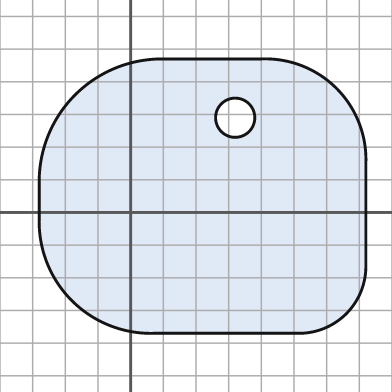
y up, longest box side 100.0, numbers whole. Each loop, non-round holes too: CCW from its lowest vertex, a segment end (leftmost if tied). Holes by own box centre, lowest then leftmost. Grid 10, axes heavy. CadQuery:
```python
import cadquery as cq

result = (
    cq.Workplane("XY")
    .moveTo(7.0, -37.0)
    .lineTo(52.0, -37.0)
    .threePointArc((66.0, -31.0), (72.0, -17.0))
    .lineTo(72.0, 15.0)
    .threePointArc((63.0, 38.0), (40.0, 47.0))
    .lineTo(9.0, 47.0)
    .threePointArc((-17.0, 36.0), (-28.0, 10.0))
    .lineTo(-28.0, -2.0)
    .threePointArc((-18.0, -27.0), (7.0, -37.0))
    .close()
    .moveTo(32.0, 29.0)
    .circle(6.0)
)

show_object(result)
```